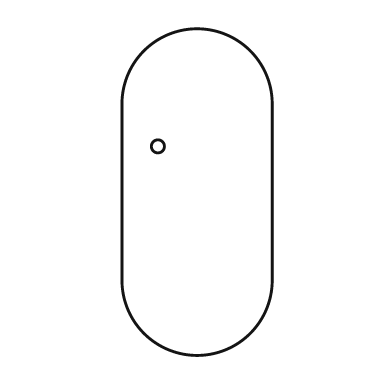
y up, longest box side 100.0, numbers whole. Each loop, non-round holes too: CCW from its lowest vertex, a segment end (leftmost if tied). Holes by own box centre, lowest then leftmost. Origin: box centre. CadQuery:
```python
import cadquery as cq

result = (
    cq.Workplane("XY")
    .moveTo(-23.0, -27.0)
    .threePointArc((0.0, -50.0), (23.0, -27.0))
    .lineTo(23.0, 27.0)
    .threePointArc((0.0, 50.0), (-23.0, 27.0))
    .close()
    .moveTo(-12.0, 14.0)
    .circle(2.0)
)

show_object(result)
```